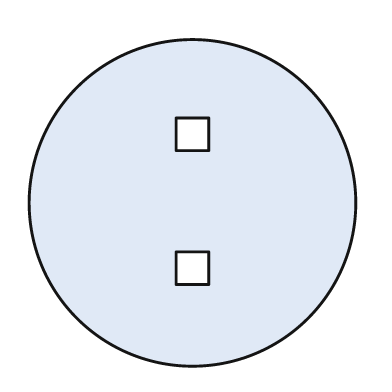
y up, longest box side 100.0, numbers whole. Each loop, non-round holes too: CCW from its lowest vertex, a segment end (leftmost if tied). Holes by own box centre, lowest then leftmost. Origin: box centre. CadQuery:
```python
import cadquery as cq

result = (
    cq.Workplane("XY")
    .moveTo(0.0, 0.0)
    .circle(50.0)
    .moveTo(-5.0, -25.0)
    .lineTo(5.0, -25.0)
    .lineTo(5.0, -15.0)
    .lineTo(-5.0, -15.0)
    .close()
    .moveTo(-5.0, 16.0)
    .lineTo(5.0, 16.0)
    .lineTo(5.0, 26.0)
    .lineTo(-5.0, 26.0)
    .close()
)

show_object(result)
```